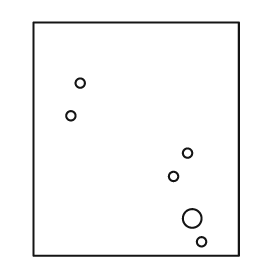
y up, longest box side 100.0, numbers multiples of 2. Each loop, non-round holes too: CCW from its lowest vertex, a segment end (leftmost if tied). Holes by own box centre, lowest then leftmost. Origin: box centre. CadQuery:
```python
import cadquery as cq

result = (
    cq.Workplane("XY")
    .moveTo(-44.0, -50.0)
    .lineTo(44.0, -50.0)
    .lineTo(44.0, 50.0)
    .lineTo(-44.0, 50.0)
    .close()
    .moveTo(28.0, -44.0)
    .circle(2.0)
    .moveTo(24.0, -34.0)
    .circle(4.0)
    .moveTo(16.0, -16.0)
    .circle(2.0)
    .moveTo(22.0, -6.0)
    .circle(2.0)
    .moveTo(-28.0, 10.0)
    .circle(2.0)
    .moveTo(-24.0, 24.0)
    .circle(2.0)
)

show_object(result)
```